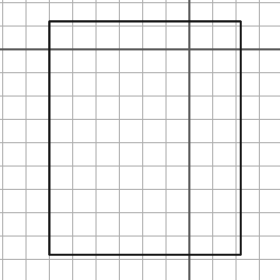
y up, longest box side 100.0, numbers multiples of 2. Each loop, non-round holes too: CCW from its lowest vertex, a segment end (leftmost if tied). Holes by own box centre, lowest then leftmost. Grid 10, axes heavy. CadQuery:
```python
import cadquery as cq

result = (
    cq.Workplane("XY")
    .moveTo(-60.0, -88.0)
    .lineTo(22.0, -88.0)
    .lineTo(22.0, 12.0)
    .lineTo(-60.0, 12.0)
    .close()
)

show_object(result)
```